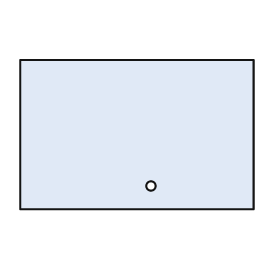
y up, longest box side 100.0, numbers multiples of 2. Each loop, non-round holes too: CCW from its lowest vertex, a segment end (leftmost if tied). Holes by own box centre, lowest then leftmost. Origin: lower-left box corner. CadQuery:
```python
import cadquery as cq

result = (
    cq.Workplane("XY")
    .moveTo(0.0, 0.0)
    .lineTo(100.0, 0.0)
    .lineTo(100.0, 64.0)
    .lineTo(0.0, 64.0)
    .close()
    .moveTo(56.0, 10.0)
    .circle(2.0)
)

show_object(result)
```